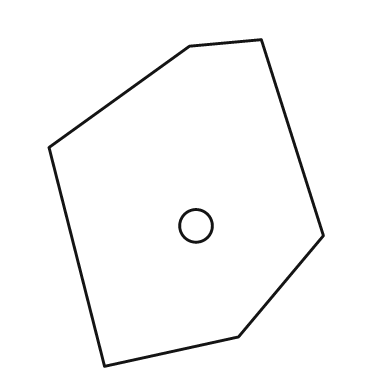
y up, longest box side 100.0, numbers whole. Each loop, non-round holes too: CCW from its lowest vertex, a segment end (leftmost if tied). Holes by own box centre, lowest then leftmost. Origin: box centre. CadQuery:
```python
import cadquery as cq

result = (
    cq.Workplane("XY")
    .moveTo(-25.0, -50.0)
    .lineTo(16.0, -41.0)
    .lineTo(42.0, -10.0)
    .lineTo(23.0, 50.0)
    .lineTo(1.0, 48.0)
    .lineTo(-42.0, 17.0)
    .close()
    .moveTo(3.0, -7.0)
    .circle(5.0)
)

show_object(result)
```